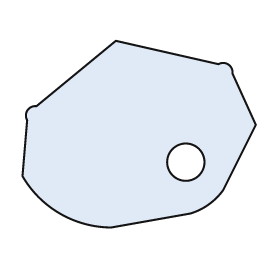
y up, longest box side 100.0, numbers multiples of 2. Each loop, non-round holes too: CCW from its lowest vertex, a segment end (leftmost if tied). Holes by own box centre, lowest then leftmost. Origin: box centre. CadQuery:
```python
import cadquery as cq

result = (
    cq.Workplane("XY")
    .moveTo(-12.0, -40.0)
    .lineTo(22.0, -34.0)
    .threePointArc((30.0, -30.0), (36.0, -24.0))
    .lineTo(50.0, 4.0)
    .lineTo(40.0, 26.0)
    .threePointArc((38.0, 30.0), (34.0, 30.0))
    .lineTo(-10.0, 40.0)
    .lineTo(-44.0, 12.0)
    .threePointArc((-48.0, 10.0), (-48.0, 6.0))
    .lineTo(-50.0, -18.0)
    .threePointArc((-34.0, -34.0), (-12.0, -40.0))
    .close()
    .moveTo(20.0, -12.0)
    .circle(8.0)
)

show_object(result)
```